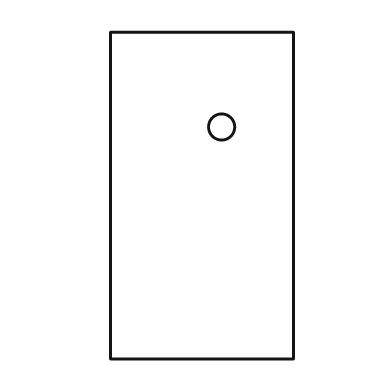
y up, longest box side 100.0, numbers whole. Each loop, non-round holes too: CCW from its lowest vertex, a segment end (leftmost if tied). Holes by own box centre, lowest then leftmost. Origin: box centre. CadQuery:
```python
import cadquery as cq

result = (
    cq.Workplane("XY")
    .moveTo(-28.0, -50.0)
    .lineTo(28.0, -50.0)
    .lineTo(28.0, 50.0)
    .lineTo(-28.0, 50.0)
    .close()
    .moveTo(6.0, 21.0)
    .circle(4.0)
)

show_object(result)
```